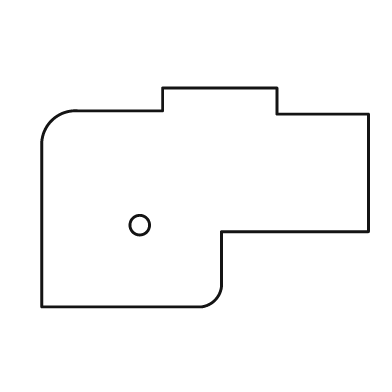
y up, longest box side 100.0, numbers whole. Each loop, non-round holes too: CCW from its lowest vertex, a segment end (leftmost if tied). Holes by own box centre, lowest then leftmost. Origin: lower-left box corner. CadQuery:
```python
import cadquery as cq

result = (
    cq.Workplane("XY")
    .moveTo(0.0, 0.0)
    .lineTo(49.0, 0.0)
    .threePointArc((53.0, 2.0), (55.0, 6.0))
    .lineTo(55.0, 23.0)
    .lineTo(100.0, 23.0)
    .lineTo(100.0, 59.0)
    .lineTo(72.0, 59.0)
    .lineTo(72.0, 67.0)
    .lineTo(37.0, 67.0)
    .lineTo(37.0, 60.0)
    .lineTo(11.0, 60.0)
    .threePointArc((3.0, 57.0), (0.0, 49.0))
    .close()
    .moveTo(30.0, 25.0)
    .circle(3.0)
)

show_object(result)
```